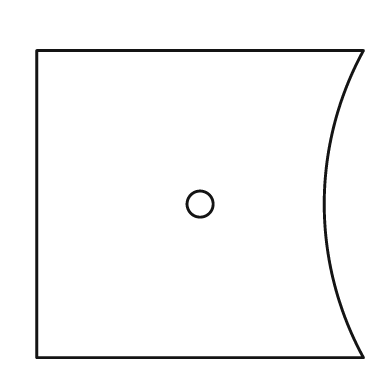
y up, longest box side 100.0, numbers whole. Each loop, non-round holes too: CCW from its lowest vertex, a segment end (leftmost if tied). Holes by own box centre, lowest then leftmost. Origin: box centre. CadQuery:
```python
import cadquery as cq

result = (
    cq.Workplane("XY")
    .moveTo(-50.0, -47.0)
    .lineTo(50.0, -47.0)
    .threePointArc((38.0, 0.0), (50.0, 47.0))
    .lineTo(-50.0, 47.0)
    .close()
    .moveTo(0.0, 0.0)
    .circle(4.0)
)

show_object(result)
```